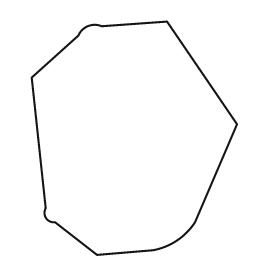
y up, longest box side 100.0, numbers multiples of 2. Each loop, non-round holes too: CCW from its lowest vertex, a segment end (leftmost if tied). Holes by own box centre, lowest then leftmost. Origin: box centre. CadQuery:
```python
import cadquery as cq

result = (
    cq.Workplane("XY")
    .moveTo(-16.0, -50.0)
    .lineTo(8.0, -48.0)
    .threePointArc((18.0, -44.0), (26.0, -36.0))
    .lineTo(44.0, 6.0)
    .lineTo(14.0, 50.0)
    .lineTo(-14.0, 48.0)
    .threePointArc((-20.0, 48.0), (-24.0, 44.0))
    .lineTo(-44.0, 26.0)
    .lineTo(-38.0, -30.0)
    .threePointArc((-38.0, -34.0), (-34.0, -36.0))
    .close()
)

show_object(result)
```